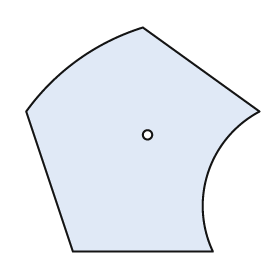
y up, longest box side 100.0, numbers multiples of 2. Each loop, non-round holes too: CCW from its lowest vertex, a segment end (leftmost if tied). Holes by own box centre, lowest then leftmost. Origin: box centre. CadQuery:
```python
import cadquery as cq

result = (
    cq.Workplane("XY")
    .moveTo(-30.0, -48.0)
    .lineTo(30.0, -48.0)
    .threePointArc((28.0, -14.0), (50.0, 12.0))
    .lineTo(0.0, 48.0)
    .threePointArc((-28.0, 34.0), (-50.0, 12.0))
    .close()
    .moveTo(2.0, 2.0)
    .circle(2.0)
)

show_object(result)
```